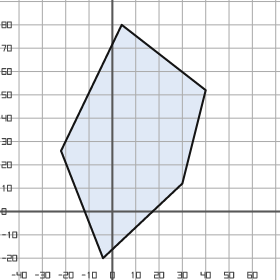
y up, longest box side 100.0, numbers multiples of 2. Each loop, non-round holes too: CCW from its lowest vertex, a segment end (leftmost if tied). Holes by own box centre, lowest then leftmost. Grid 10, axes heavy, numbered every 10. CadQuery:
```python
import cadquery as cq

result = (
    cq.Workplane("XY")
    .moveTo(-4.0, -20.0)
    .lineTo(30.0, 12.0)
    .lineTo(40.0, 52.0)
    .lineTo(4.0, 80.0)
    .lineTo(-22.0, 26.0)
    .close()
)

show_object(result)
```